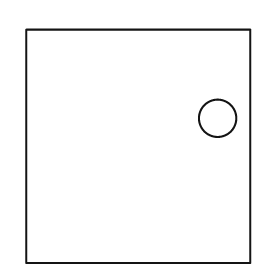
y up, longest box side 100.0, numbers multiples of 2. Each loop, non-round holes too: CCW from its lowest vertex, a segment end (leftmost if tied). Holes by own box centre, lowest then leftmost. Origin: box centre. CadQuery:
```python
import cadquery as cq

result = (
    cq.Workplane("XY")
    .moveTo(-48.0, -50.0)
    .lineTo(48.0, -50.0)
    .lineTo(48.0, 50.0)
    .lineTo(-48.0, 50.0)
    .close()
    .moveTo(34.0, 12.0)
    .circle(8.0)
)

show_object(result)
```